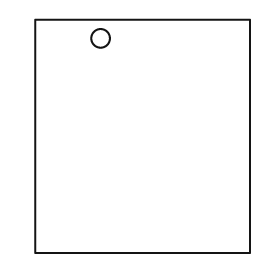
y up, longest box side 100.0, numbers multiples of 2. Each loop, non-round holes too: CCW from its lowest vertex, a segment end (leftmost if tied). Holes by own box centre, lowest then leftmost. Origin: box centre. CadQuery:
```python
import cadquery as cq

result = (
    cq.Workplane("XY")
    .moveTo(-46.0, -50.0)
    .lineTo(46.0, -50.0)
    .lineTo(46.0, 50.0)
    .lineTo(-46.0, 50.0)
    .close()
    .moveTo(-18.0, 42.0)
    .circle(4.0)
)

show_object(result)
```